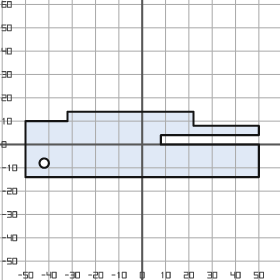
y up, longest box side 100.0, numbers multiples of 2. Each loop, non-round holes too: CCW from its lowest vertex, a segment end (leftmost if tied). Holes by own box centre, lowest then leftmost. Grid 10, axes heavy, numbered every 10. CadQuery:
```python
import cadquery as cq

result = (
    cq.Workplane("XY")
    .moveTo(-50.0, -14.0)
    .lineTo(50.0, -14.0)
    .lineTo(50.0, 0.0)
    .lineTo(8.0, 0.0)
    .lineTo(8.0, 4.0)
    .lineTo(50.0, 4.0)
    .lineTo(50.0, 8.0)
    .lineTo(22.0, 8.0)
    .lineTo(22.0, 14.0)
    .lineTo(-32.0, 14.0)
    .lineTo(-32.0, 10.0)
    .lineTo(-50.0, 10.0)
    .close()
    .moveTo(-42.0, -8.0)
    .circle(2.0)
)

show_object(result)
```